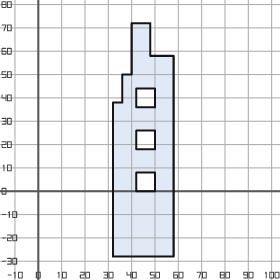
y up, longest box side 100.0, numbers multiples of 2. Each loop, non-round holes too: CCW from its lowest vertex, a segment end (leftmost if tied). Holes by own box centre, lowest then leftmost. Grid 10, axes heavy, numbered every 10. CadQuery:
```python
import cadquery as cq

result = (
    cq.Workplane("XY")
    .moveTo(32.0, -28.0)
    .lineTo(58.0, -28.0)
    .lineTo(58.0, 58.0)
    .lineTo(48.0, 58.0)
    .lineTo(48.0, 72.0)
    .lineTo(40.0, 72.0)
    .lineTo(40.0, 50.0)
    .lineTo(36.0, 50.0)
    .lineTo(36.0, 38.0)
    .lineTo(32.0, 38.0)
    .close()
    .moveTo(42.0, 0.0)
    .lineTo(50.0, 0.0)
    .lineTo(50.0, 8.0)
    .lineTo(42.0, 8.0)
    .close()
    .moveTo(42.0, 18.0)
    .lineTo(50.0, 18.0)
    .lineTo(50.0, 26.0)
    .lineTo(42.0, 26.0)
    .close()
    .moveTo(42.0, 36.0)
    .lineTo(50.0, 36.0)
    .lineTo(50.0, 44.0)
    .lineTo(42.0, 44.0)
    .close()
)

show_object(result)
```